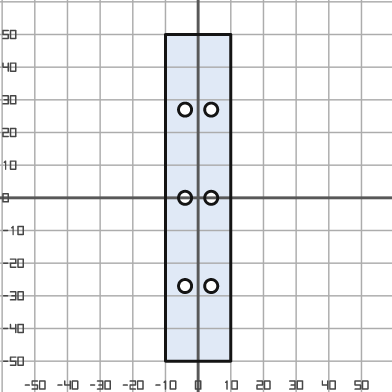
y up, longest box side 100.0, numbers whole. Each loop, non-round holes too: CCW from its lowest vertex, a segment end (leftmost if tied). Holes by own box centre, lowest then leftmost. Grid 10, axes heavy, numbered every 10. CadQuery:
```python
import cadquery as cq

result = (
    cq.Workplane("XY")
    .moveTo(-10.0, -50.0)
    .lineTo(10.0, -50.0)
    .lineTo(10.0, 50.0)
    .lineTo(-10.0, 50.0)
    .close()
    .moveTo(-4.0, -27.0)
    .circle(2.0)
    .moveTo(4.0, -27.0)
    .circle(2.0)
    .moveTo(-4.0, 0.0)
    .circle(2.0)
    .moveTo(4.0, 0.0)
    .circle(2.0)
    .moveTo(-4.0, 27.0)
    .circle(2.0)
    .moveTo(4.0, 27.0)
    .circle(2.0)
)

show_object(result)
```